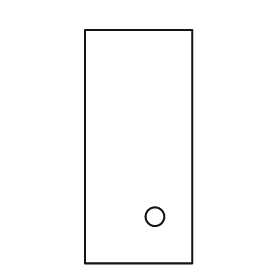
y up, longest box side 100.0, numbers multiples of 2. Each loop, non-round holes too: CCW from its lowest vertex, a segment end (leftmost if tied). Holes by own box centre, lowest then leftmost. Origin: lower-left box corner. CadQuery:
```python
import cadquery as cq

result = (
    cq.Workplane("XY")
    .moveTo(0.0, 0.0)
    .lineTo(46.0, 0.0)
    .lineTo(46.0, 100.0)
    .lineTo(0.0, 100.0)
    .close()
    .moveTo(30.0, 20.0)
    .circle(4.0)
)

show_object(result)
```